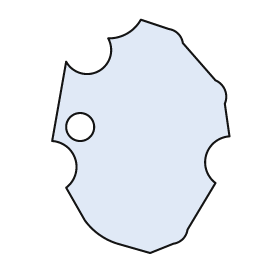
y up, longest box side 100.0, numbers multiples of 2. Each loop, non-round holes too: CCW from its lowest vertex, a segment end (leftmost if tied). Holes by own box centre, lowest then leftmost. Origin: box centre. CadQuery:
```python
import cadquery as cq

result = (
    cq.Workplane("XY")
    .moveTo(4.0, -50.0)
    .lineTo(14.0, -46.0)
    .threePointArc((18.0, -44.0), (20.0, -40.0))
    .lineTo(32.0, -20.0)
    .threePointArc((28.0, -8.0), (38.0, 0.0))
    .lineTo(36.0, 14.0)
    .threePointArc((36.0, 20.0), (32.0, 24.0))
    .lineTo(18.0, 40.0)
    .threePointArc((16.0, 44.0), (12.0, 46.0))
    .lineTo(0.0, 50.0)
    .threePointArc((-6.0, 44.0), (-14.0, 42.0))
    .threePointArc((-18.0, 28.0), (-32.0, 32.0))
    .lineTo(-38.0, -2.0)
    .threePointArc((-28.0, -10.0), (-32.0, -22.0))
    .lineTo(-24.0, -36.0)
    .threePointArc((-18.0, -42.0), (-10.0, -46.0))
    .close()
    .moveTo(-26.0, 4.0)
    .circle(6.0)
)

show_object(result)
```